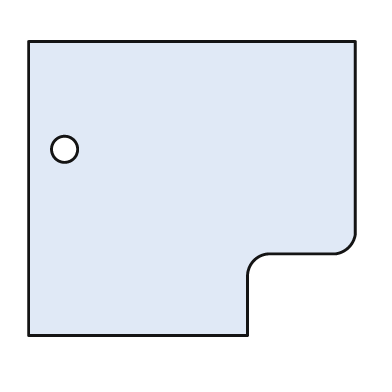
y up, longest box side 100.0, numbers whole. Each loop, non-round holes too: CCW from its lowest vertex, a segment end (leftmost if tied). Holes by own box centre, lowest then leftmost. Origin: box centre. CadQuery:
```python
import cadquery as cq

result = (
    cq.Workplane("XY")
    .moveTo(-50.0, -45.0)
    .lineTo(17.0, -45.0)
    .lineTo(17.0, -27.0)
    .threePointArc((19.0, -22.0), (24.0, -20.0))
    .lineTo(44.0, -20.0)
    .threePointArc((48.0, -18.0), (50.0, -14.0))
    .lineTo(50.0, 45.0)
    .lineTo(-50.0, 45.0)
    .close()
    .moveTo(-39.0, 12.0)
    .circle(4.0)
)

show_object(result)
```